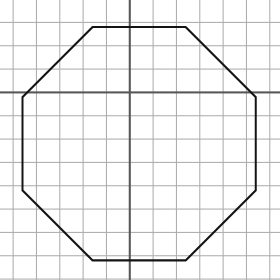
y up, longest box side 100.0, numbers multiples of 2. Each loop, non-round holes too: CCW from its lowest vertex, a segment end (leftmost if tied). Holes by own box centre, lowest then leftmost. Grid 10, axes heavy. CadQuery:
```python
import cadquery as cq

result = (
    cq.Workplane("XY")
    .moveTo(-16.0, -72.0)
    .lineTo(24.0, -72.0)
    .lineTo(54.0, -42.0)
    .lineTo(54.0, -2.0)
    .lineTo(24.0, 28.0)
    .lineTo(-16.0, 28.0)
    .lineTo(-46.0, -2.0)
    .lineTo(-46.0, -42.0)
    .close()
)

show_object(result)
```